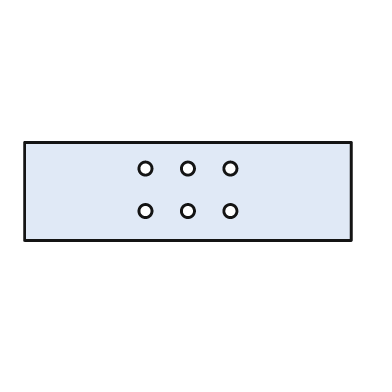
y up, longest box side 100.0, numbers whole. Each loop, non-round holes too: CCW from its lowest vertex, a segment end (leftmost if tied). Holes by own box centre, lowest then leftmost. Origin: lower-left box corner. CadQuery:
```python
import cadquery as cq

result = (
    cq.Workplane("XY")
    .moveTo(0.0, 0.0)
    .lineTo(100.0, 0.0)
    .lineTo(100.0, 30.0)
    .lineTo(0.0, 30.0)
    .close()
    .moveTo(37.0, 9.0)
    .circle(2.0)
    .moveTo(50.0, 9.0)
    .circle(2.0)
    .moveTo(63.0, 9.0)
    .circle(2.0)
    .moveTo(37.0, 22.0)
    .circle(2.0)
    .moveTo(50.0, 22.0)
    .circle(2.0)
    .moveTo(63.0, 22.0)
    .circle(2.0)
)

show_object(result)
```